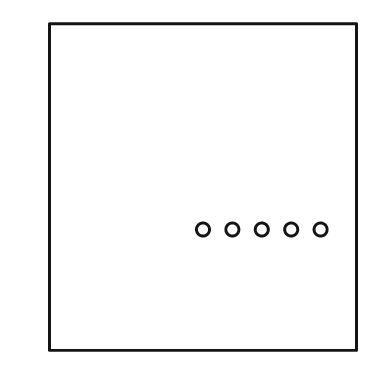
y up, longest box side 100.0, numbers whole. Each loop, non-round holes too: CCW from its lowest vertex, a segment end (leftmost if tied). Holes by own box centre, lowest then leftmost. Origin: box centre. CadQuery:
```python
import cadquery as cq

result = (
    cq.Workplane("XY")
    .moveTo(-47.0, -50.0)
    .lineTo(47.0, -50.0)
    .lineTo(47.0, 50.0)
    .lineTo(-47.0, 50.0)
    .close()
    .moveTo(0.0, -13.0)
    .circle(2.0)
    .moveTo(9.0, -13.0)
    .circle(2.0)
    .moveTo(18.0, -13.0)
    .circle(2.0)
    .moveTo(27.0, -13.0)
    .circle(2.0)
    .moveTo(36.0, -13.0)
    .circle(2.0)
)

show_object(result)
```